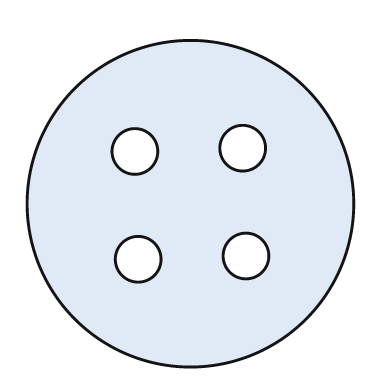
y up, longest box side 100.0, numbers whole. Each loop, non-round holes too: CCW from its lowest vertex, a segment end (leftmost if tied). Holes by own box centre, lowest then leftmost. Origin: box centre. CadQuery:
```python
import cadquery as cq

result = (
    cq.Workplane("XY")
    .moveTo(0.0, 0.0)
    .circle(50.0)
    .moveTo(-16.0, -17.0)
    .circle(7.0)
    .moveTo(17.0, -16.0)
    .circle(7.0)
    .moveTo(-17.0, 16.0)
    .circle(7.0)
    .moveTo(16.0, 17.0)
    .circle(7.0)
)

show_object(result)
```